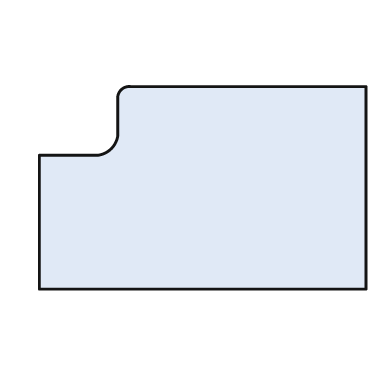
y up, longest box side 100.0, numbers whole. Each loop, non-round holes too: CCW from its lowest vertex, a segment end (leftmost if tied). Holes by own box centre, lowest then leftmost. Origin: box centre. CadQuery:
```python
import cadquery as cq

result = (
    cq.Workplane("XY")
    .moveTo(-50.0, -31.0)
    .lineTo(50.0, -31.0)
    .lineTo(50.0, 31.0)
    .lineTo(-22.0, 31.0)
    .threePointArc((-25.0, 30.0), (-26.0, 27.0))
    .lineTo(-26.0, 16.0)
    .threePointArc((-28.0, 12.0), (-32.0, 10.0))
    .lineTo(-50.0, 10.0)
    .close()
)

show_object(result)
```